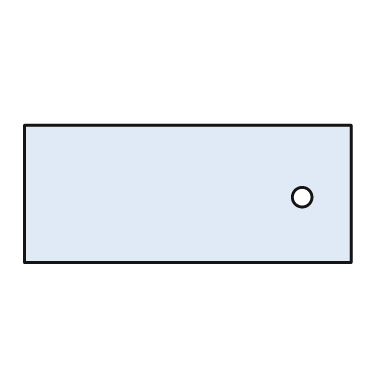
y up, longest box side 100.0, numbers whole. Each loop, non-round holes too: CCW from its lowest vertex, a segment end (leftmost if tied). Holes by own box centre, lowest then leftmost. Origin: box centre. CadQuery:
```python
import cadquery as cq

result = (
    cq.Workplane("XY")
    .moveTo(-50.0, -21.0)
    .lineTo(50.0, -21.0)
    .lineTo(50.0, 21.0)
    .lineTo(-50.0, 21.0)
    .close()
    .moveTo(35.0, -1.0)
    .circle(3.0)
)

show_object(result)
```